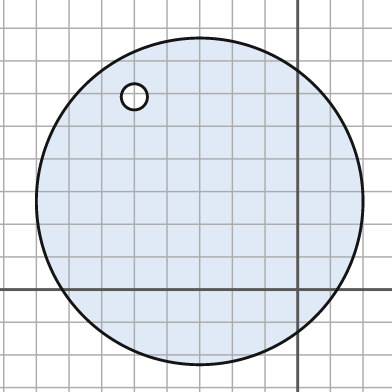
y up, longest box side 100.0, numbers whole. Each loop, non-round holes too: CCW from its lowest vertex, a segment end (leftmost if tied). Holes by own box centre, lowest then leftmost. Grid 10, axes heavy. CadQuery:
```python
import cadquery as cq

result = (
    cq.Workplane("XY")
    .moveTo(-30.0, 27.0)
    .circle(50.0)
    .moveTo(-50.0, 59.0)
    .circle(4.0)
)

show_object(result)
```